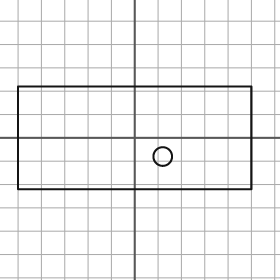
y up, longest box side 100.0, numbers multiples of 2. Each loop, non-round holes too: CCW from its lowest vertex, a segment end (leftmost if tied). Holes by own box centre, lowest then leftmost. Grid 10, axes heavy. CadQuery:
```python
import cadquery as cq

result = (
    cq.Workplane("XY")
    .moveTo(-50.0, -22.0)
    .lineTo(50.0, -22.0)
    .lineTo(50.0, 22.0)
    .lineTo(-50.0, 22.0)
    .close()
    .moveTo(12.0, -8.0)
    .circle(4.0)
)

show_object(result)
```